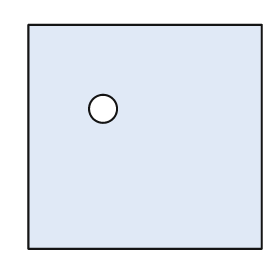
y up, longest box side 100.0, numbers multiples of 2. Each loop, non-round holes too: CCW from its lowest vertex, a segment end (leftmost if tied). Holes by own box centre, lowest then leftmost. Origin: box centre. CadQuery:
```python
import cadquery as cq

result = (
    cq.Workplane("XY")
    .moveTo(-50.0, -48.0)
    .lineTo(50.0, -48.0)
    .lineTo(50.0, 48.0)
    .lineTo(-50.0, 48.0)
    .close()
    .moveTo(-18.0, 12.0)
    .circle(6.0)
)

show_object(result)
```